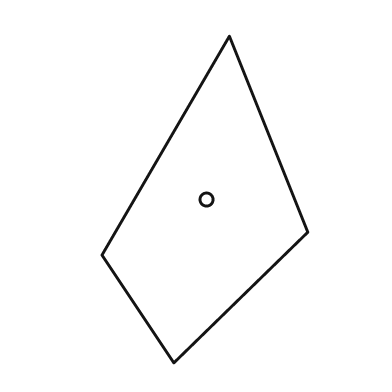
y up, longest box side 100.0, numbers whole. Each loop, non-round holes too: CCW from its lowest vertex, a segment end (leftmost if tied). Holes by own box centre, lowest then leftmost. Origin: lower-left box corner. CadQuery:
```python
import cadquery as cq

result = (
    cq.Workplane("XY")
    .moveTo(22.0, 0.0)
    .lineTo(63.0, 40.0)
    .lineTo(39.0, 100.0)
    .lineTo(0.0, 33.0)
    .close()
    .moveTo(32.0, 50.0)
    .circle(2.0)
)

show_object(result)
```